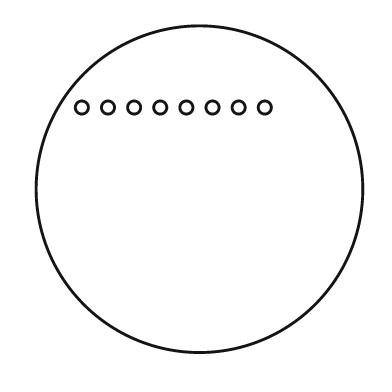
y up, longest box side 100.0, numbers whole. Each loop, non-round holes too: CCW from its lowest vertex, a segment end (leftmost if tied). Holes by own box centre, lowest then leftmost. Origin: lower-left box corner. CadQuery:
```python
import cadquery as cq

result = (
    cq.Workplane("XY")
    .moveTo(50.0, 50.0)
    .circle(50.0)
    .moveTo(14.0, 75.0)
    .circle(2.0)
    .moveTo(22.0, 75.0)
    .circle(2.0)
    .moveTo(30.0, 75.0)
    .circle(2.0)
    .moveTo(38.0, 75.0)
    .circle(2.0)
    .moveTo(46.0, 75.0)
    .circle(2.0)
    .moveTo(54.0, 75.0)
    .circle(2.0)
    .moveTo(62.0, 75.0)
    .circle(2.0)
    .moveTo(70.0, 75.0)
    .circle(2.0)
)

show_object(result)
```